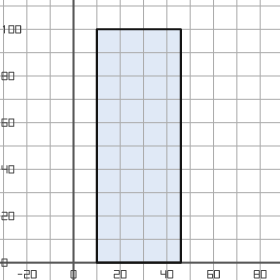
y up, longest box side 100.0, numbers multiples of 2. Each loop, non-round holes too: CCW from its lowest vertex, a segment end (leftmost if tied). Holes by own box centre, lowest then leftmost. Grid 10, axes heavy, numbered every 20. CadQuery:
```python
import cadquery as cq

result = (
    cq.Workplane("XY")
    .moveTo(10.0, 0.0)
    .lineTo(46.0, 0.0)
    .lineTo(46.0, 100.0)
    .lineTo(10.0, 100.0)
    .close()
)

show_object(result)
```